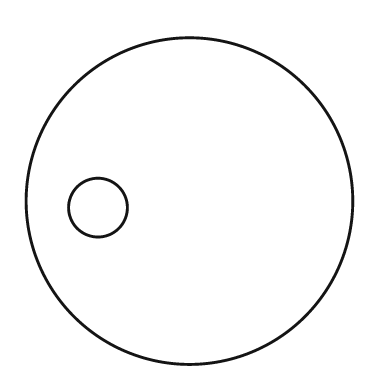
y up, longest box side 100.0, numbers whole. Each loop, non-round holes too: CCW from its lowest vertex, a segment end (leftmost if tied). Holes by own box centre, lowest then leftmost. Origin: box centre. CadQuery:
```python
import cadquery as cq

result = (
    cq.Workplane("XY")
    .moveTo(0.0, 0.0)
    .circle(50.0)
    .moveTo(-28.0, -2.0)
    .circle(9.0)
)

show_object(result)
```